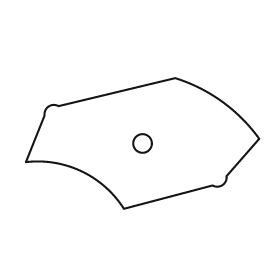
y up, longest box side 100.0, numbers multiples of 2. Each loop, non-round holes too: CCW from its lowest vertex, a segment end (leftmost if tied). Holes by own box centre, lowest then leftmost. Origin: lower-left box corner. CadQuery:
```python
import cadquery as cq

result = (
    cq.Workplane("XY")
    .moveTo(42.0, 0.0)
    .lineTo(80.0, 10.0)
    .threePointArc((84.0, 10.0), (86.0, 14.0))
    .lineTo(100.0, 30.0)
    .threePointArc((84.0, 46.0), (64.0, 56.0))
    .lineTo(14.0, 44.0)
    .threePointArc((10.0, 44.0), (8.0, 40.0))
    .lineTo(0.0, 20.0)
    .threePointArc((24.0, 16.0), (42.0, 0.0))
    .close()
    .moveTo(50.0, 28.0)
    .circle(4.0)
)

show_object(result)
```